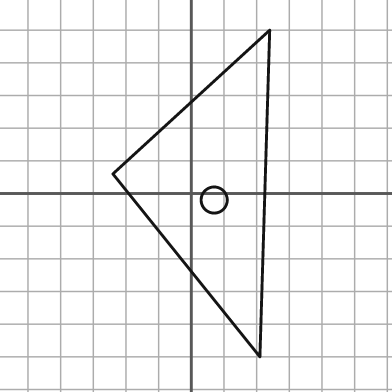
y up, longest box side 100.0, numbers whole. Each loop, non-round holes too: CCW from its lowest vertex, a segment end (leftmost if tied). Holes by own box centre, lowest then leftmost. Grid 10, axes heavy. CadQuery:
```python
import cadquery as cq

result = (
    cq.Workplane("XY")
    .moveTo(21.0, -50.0)
    .lineTo(24.0, 50.0)
    .lineTo(-24.0, 6.0)
    .close()
    .moveTo(7.0, -2.0)
    .circle(4.0)
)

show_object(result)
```